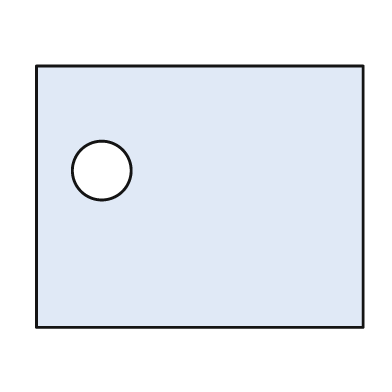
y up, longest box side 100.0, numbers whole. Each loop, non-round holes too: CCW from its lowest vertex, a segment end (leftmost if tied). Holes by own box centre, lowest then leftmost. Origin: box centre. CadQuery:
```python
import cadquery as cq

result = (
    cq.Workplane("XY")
    .moveTo(-50.0, -40.0)
    .lineTo(50.0, -40.0)
    .lineTo(50.0, 40.0)
    .lineTo(-50.0, 40.0)
    .close()
    .moveTo(-30.0, 8.0)
    .circle(9.0)
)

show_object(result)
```